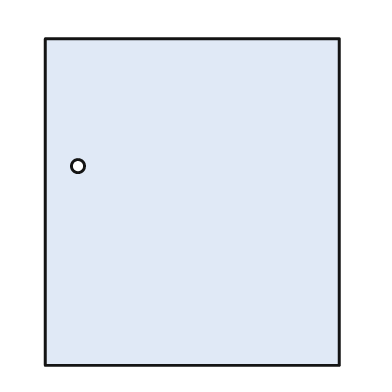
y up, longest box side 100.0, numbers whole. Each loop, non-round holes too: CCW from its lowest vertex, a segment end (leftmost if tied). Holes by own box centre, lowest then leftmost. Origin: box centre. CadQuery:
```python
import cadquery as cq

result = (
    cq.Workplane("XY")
    .moveTo(-45.0, -50.0)
    .lineTo(45.0, -50.0)
    .lineTo(45.0, 50.0)
    .lineTo(-45.0, 50.0)
    .close()
    .moveTo(-35.0, 11.0)
    .circle(2.0)
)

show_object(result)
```